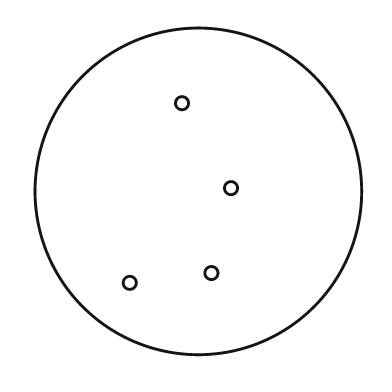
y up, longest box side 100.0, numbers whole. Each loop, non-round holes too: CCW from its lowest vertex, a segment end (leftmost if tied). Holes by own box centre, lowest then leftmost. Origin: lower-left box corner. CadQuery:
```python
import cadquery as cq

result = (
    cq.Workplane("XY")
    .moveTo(50.0, 50.0)
    .circle(50.0)
    .moveTo(29.0, 22.0)
    .circle(2.0)
    .moveTo(54.0, 25.0)
    .circle(2.0)
    .moveTo(60.0, 51.0)
    .circle(2.0)
    .moveTo(45.0, 77.0)
    .circle(2.0)
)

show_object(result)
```